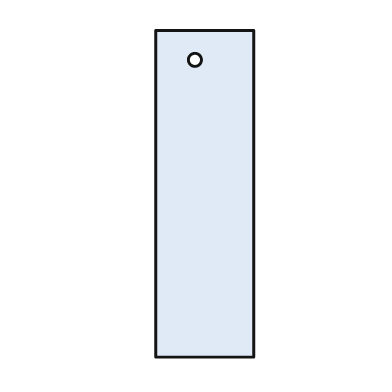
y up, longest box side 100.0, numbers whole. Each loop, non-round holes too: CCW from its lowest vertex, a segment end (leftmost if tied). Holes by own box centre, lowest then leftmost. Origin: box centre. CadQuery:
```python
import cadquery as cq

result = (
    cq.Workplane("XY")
    .moveTo(-15.0, -50.0)
    .lineTo(15.0, -50.0)
    .lineTo(15.0, 50.0)
    .lineTo(-15.0, 50.0)
    .close()
    .moveTo(-3.0, 41.0)
    .circle(2.0)
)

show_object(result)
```